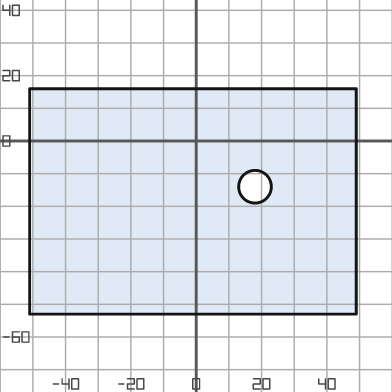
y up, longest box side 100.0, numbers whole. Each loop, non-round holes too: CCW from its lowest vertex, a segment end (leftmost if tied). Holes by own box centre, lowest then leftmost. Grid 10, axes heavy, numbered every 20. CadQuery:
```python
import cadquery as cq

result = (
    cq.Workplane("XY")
    .moveTo(-51.0, -53.0)
    .lineTo(49.0, -53.0)
    .lineTo(49.0, 16.0)
    .lineTo(-51.0, 16.0)
    .close()
    .moveTo(18.0, -14.0)
    .circle(5.0)
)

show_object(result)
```